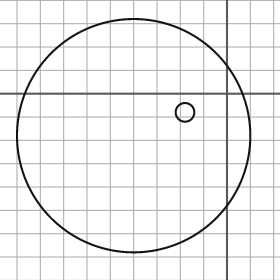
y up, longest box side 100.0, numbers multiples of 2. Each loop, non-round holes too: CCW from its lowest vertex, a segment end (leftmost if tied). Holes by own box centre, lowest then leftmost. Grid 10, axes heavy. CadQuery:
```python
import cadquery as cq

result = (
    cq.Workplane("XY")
    .moveTo(-40.0, -18.0)
    .circle(50.0)
    .moveTo(-18.0, -8.0)
    .circle(4.0)
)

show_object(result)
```